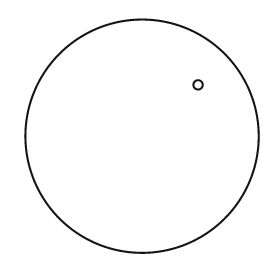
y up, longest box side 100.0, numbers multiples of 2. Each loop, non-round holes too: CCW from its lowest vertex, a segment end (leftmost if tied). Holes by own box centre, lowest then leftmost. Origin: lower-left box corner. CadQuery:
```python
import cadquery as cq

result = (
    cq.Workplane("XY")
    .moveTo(50.0, 50.0)
    .circle(50.0)
    .moveTo(74.0, 72.0)
    .circle(2.0)
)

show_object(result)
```